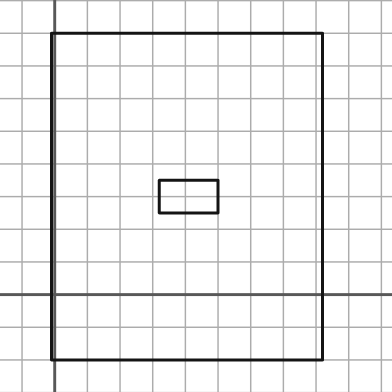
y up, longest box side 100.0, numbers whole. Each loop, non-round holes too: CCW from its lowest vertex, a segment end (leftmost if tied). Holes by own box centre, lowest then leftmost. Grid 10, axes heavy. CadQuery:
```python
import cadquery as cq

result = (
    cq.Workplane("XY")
    .moveTo(-1.0, -20.0)
    .lineTo(82.0, -20.0)
    .lineTo(82.0, 80.0)
    .lineTo(-1.0, 80.0)
    .close()
    .moveTo(32.0, 25.0)
    .lineTo(50.0, 25.0)
    .lineTo(50.0, 35.0)
    .lineTo(32.0, 35.0)
    .close()
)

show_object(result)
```